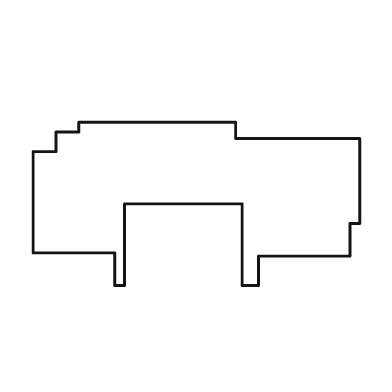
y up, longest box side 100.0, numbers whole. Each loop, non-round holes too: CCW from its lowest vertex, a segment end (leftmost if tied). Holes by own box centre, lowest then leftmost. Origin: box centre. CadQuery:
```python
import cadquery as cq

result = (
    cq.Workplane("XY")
    .moveTo(-25.0, -25.0)
    .lineTo(-22.0, -25.0)
    .lineTo(-22.0, 0.0)
    .lineTo(14.0, 0.0)
    .lineTo(14.0, -25.0)
    .lineTo(19.0, -25.0)
    .lineTo(19.0, -16.0)
    .lineTo(47.0, -16.0)
    .lineTo(47.0, -6.0)
    .lineTo(50.0, -6.0)
    .lineTo(50.0, 20.0)
    .lineTo(12.0, 20.0)
    .lineTo(12.0, 25.0)
    .lineTo(-36.0, 25.0)
    .lineTo(-36.0, 22.0)
    .lineTo(-43.0, 22.0)
    .lineTo(-43.0, 16.0)
    .lineTo(-50.0, 16.0)
    .lineTo(-50.0, -15.0)
    .lineTo(-25.0, -15.0)
    .close()
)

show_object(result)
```